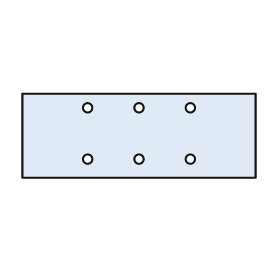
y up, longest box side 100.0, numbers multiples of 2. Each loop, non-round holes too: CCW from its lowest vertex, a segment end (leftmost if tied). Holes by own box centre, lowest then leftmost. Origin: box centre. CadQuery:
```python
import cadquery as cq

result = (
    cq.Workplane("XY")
    .moveTo(-50.0, -18.0)
    .lineTo(50.0, -18.0)
    .lineTo(50.0, 18.0)
    .lineTo(-50.0, 18.0)
    .close()
    .moveTo(-22.0, -10.0)
    .circle(2.0)
    .moveTo(0.0, -10.0)
    .circle(2.0)
    .moveTo(22.0, -10.0)
    .circle(2.0)
    .moveTo(-22.0, 12.0)
    .circle(2.0)
    .moveTo(0.0, 12.0)
    .circle(2.0)
    .moveTo(22.0, 12.0)
    .circle(2.0)
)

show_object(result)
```